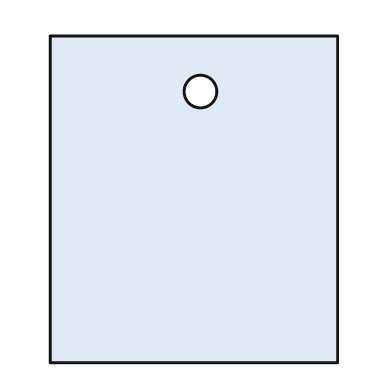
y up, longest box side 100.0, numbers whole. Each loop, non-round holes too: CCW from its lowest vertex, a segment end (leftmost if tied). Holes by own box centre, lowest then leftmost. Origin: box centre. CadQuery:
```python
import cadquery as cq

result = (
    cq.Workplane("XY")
    .moveTo(-44.0, -50.0)
    .lineTo(44.0, -50.0)
    .lineTo(44.0, 50.0)
    .lineTo(-44.0, 50.0)
    .close()
    .moveTo(2.0, 33.0)
    .circle(5.0)
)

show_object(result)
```